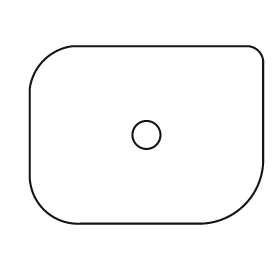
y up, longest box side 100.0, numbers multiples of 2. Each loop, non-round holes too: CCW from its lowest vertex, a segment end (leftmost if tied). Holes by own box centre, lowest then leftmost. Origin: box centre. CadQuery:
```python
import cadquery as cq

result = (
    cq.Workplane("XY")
    .moveTo(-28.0, -38.0)
    .lineTo(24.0, -38.0)
    .threePointArc((42.0, -30.0), (50.0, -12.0))
    .lineTo(50.0, 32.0)
    .threePointArc((48.0, 36.0), (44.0, 38.0))
    .lineTo(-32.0, 38.0)
    .threePointArc((-44.0, 32.0), (-50.0, 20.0))
    .lineTo(-50.0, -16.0)
    .threePointArc((-44.0, -32.0), (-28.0, -38.0))
    .close()
    .moveTo(0.0, 0.0)
    .circle(6.0)
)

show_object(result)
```